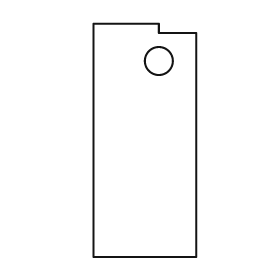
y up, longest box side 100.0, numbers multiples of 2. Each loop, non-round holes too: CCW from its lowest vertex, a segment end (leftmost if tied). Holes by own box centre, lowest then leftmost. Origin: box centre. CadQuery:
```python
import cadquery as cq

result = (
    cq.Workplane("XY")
    .moveTo(-22.0, -50.0)
    .lineTo(22.0, -50.0)
    .lineTo(22.0, 46.0)
    .lineTo(6.0, 46.0)
    .lineTo(6.0, 50.0)
    .lineTo(-22.0, 50.0)
    .close()
    .moveTo(6.0, 34.0)
    .circle(6.0)
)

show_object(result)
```